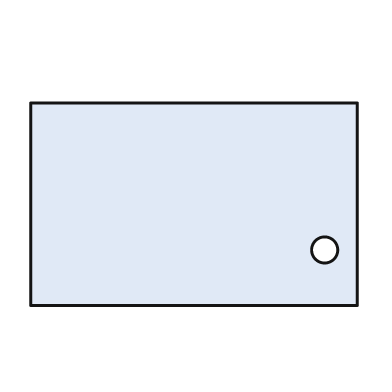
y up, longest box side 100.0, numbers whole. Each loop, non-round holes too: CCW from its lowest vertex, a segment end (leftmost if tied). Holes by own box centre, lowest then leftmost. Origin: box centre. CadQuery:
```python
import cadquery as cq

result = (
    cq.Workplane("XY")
    .moveTo(-50.0, -31.0)
    .lineTo(50.0, -31.0)
    .lineTo(50.0, 31.0)
    .lineTo(-50.0, 31.0)
    .close()
    .moveTo(40.0, -14.0)
    .circle(4.0)
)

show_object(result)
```